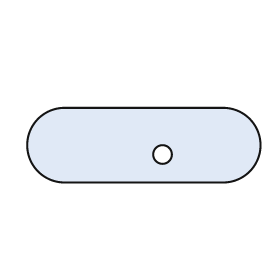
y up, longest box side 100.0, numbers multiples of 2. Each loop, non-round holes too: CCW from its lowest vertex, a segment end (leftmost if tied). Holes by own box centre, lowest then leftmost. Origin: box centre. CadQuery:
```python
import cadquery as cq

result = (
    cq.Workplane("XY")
    .moveTo(-34.0, -16.0)
    .lineTo(34.0, -16.0)
    .threePointArc((50.0, 0.0), (34.0, 16.0))
    .lineTo(-34.0, 16.0)
    .threePointArc((-50.0, 0.0), (-34.0, -16.0))
    .close()
    .moveTo(8.0, -4.0)
    .circle(4.0)
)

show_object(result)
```